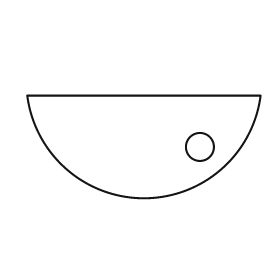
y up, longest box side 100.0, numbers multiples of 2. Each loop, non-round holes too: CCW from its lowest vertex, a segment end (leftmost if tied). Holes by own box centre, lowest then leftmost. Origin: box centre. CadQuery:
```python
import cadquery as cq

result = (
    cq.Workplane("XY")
    .moveTo(-50.0, 22.0)
    .threePointArc((0.0, -22.0), (50.0, 22.0))
    .close()
    .moveTo(24.0, 0.0)
    .circle(6.0)
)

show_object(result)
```